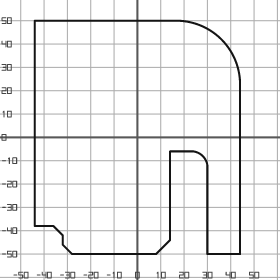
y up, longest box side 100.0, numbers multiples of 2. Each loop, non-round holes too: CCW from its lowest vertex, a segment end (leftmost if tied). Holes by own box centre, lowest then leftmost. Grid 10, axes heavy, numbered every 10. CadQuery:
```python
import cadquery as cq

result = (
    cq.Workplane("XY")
    .moveTo(-28.0, -50.0)
    .lineTo(8.0, -50.0)
    .lineTo(14.0, -44.0)
    .lineTo(14.0, -6.0)
    .lineTo(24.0, -6.0)
    .threePointArc((28.0, -8.0), (30.0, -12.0))
    .lineTo(30.0, -50.0)
    .lineTo(44.0, -50.0)
    .lineTo(44.0, 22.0)
    .threePointArc((36.0, 42.0), (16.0, 50.0))
    .lineTo(-44.0, 50.0)
    .lineTo(-44.0, -38.0)
    .lineTo(-36.0, -38.0)
    .lineTo(-32.0, -42.0)
    .lineTo(-32.0, -46.0)
    .close()
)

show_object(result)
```